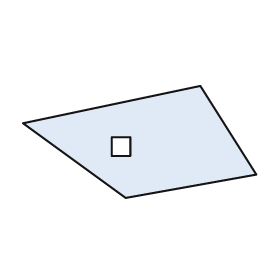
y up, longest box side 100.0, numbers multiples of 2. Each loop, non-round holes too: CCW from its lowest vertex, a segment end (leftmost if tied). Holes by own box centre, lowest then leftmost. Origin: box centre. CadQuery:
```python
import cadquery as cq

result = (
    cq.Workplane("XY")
    .moveTo(-6.0, -24.0)
    .lineTo(50.0, -14.0)
    .lineTo(26.0, 24.0)
    .lineTo(-50.0, 8.0)
    .close()
    .moveTo(-12.0, -6.0)
    .lineTo(-4.0, -6.0)
    .lineTo(-4.0, 2.0)
    .lineTo(-12.0, 2.0)
    .close()
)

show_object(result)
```